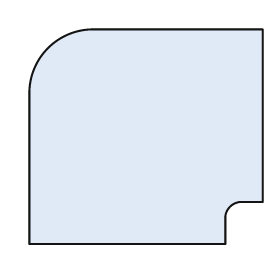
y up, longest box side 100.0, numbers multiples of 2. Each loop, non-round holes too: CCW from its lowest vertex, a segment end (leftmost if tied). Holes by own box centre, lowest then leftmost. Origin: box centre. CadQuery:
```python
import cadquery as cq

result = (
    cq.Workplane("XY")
    .moveTo(-50.0, -46.0)
    .lineTo(34.0, -46.0)
    .lineTo(34.0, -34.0)
    .threePointArc((36.0, -30.0), (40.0, -28.0))
    .lineTo(50.0, -28.0)
    .lineTo(50.0, 46.0)
    .lineTo(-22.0, 46.0)
    .threePointArc((-42.0, 38.0), (-50.0, 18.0))
    .close()
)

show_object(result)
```